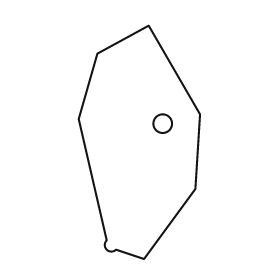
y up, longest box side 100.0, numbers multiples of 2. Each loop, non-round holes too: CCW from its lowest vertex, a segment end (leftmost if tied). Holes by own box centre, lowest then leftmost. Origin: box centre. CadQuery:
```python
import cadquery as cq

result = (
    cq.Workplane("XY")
    .moveTo(2.0, -50.0)
    .lineTo(24.0, -20.0)
    .lineTo(26.0, 12.0)
    .lineTo(4.0, 50.0)
    .lineTo(-18.0, 38.0)
    .lineTo(-26.0, 10.0)
    .lineTo(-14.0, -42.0)
    .threePointArc((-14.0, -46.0), (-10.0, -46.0))
    .close()
    .moveTo(10.0, 8.0)
    .circle(4.0)
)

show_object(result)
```